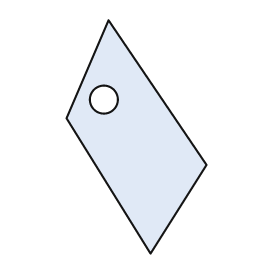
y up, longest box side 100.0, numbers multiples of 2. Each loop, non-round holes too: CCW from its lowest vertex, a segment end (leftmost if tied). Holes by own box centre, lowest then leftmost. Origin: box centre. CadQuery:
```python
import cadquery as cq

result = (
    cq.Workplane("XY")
    .moveTo(6.0, -50.0)
    .lineTo(30.0, -12.0)
    .lineTo(-12.0, 50.0)
    .lineTo(-30.0, 8.0)
    .close()
    .moveTo(-14.0, 16.0)
    .circle(6.0)
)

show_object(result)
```